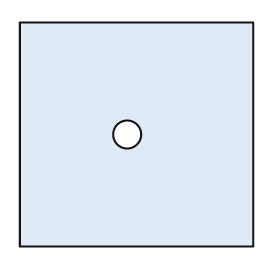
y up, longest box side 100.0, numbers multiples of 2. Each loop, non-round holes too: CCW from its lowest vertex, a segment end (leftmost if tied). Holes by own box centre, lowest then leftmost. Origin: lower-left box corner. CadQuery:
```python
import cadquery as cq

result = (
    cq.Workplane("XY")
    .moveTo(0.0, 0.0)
    .lineTo(100.0, 0.0)
    .lineTo(100.0, 96.0)
    .lineTo(0.0, 96.0)
    .close()
    .moveTo(46.0, 48.0)
    .circle(6.0)
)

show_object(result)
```